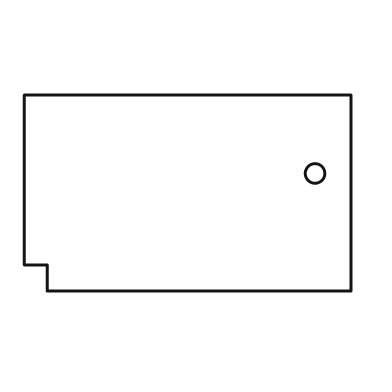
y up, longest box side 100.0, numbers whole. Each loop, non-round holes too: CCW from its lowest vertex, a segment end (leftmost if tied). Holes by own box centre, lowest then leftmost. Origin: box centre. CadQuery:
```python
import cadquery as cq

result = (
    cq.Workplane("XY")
    .moveTo(-43.0, -30.0)
    .lineTo(50.0, -30.0)
    .lineTo(50.0, 30.0)
    .lineTo(-50.0, 30.0)
    .lineTo(-50.0, -22.0)
    .lineTo(-43.0, -22.0)
    .close()
    .moveTo(39.0, 6.0)
    .circle(3.0)
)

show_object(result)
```